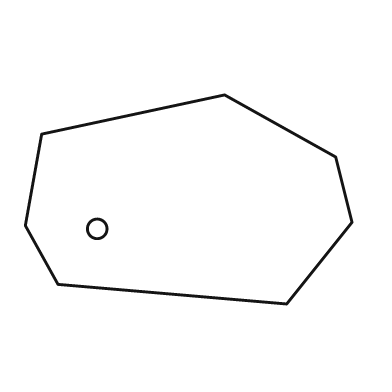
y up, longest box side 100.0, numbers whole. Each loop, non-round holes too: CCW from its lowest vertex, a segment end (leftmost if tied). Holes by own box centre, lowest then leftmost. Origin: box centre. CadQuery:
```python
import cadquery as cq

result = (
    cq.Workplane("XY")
    .moveTo(30.0, -32.0)
    .lineTo(50.0, -7.0)
    .lineTo(45.0, 13.0)
    .lineTo(11.0, 32.0)
    .lineTo(-45.0, 20.0)
    .lineTo(-50.0, -8.0)
    .lineTo(-40.0, -26.0)
    .close()
    .moveTo(-28.0, -9.0)
    .circle(3.0)
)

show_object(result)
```